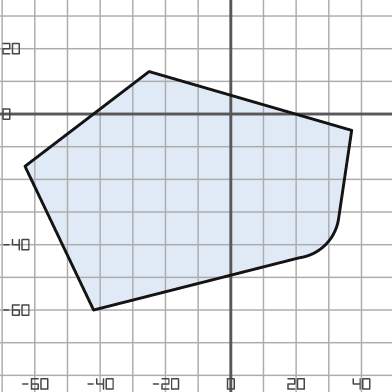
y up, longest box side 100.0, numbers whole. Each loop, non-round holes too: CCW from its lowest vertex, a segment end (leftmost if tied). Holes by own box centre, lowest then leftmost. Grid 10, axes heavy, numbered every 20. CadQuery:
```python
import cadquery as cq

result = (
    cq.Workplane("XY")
    .moveTo(-42.0, -60.0)
    .lineTo(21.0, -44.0)
    .threePointArc((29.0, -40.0), (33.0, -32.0))
    .lineTo(37.0, -5.0)
    .lineTo(-25.0, 13.0)
    .lineTo(-63.0, -16.0)
    .close()
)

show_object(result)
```